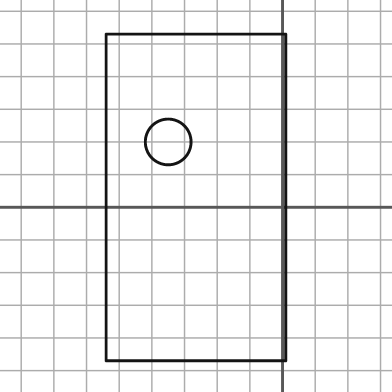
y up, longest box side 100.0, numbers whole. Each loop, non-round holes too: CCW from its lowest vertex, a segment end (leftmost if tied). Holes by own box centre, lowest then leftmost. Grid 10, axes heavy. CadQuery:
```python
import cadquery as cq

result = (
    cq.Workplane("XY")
    .moveTo(-54.0, -47.0)
    .lineTo(1.0, -47.0)
    .lineTo(1.0, 53.0)
    .lineTo(-54.0, 53.0)
    .close()
    .moveTo(-35.0, 20.0)
    .circle(7.0)
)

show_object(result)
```